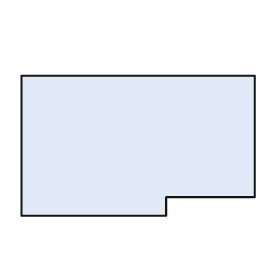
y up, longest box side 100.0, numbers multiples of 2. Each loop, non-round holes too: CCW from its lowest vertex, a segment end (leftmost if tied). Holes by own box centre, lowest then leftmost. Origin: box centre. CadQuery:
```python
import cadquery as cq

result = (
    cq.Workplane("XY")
    .moveTo(-50.0, -30.0)
    .lineTo(12.0, -30.0)
    .lineTo(12.0, -22.0)
    .lineTo(50.0, -22.0)
    .lineTo(50.0, 30.0)
    .lineTo(-50.0, 30.0)
    .close()
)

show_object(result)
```